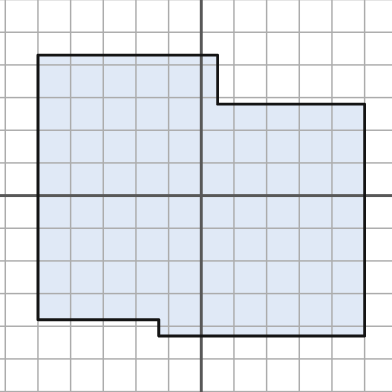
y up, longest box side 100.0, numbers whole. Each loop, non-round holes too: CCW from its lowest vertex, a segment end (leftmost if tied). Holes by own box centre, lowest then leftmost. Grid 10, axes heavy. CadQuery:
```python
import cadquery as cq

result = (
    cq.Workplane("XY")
    .moveTo(-13.0, -43.0)
    .lineTo(50.0, -43.0)
    .lineTo(50.0, 28.0)
    .lineTo(5.0, 28.0)
    .lineTo(5.0, 43.0)
    .lineTo(-50.0, 43.0)
    .lineTo(-50.0, -38.0)
    .lineTo(-13.0, -38.0)
    .close()
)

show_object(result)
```